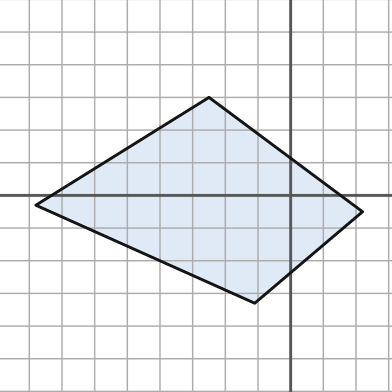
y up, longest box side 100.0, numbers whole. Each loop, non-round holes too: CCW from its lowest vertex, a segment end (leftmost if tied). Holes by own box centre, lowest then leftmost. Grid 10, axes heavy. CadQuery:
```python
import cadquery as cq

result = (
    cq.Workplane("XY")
    .moveTo(-11.0, -33.0)
    .lineTo(22.0, -5.0)
    .lineTo(-25.0, 30.0)
    .lineTo(-78.0, -3.0)
    .close()
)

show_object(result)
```